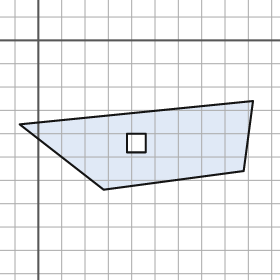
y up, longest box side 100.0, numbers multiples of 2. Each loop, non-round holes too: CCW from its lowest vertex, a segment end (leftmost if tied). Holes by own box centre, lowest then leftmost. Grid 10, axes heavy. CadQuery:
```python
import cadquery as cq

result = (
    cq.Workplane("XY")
    .moveTo(28.0, -64.0)
    .lineTo(88.0, -56.0)
    .lineTo(92.0, -26.0)
    .lineTo(-8.0, -36.0)
    .close()
    .moveTo(38.0, -48.0)
    .lineTo(46.0, -48.0)
    .lineTo(46.0, -40.0)
    .lineTo(38.0, -40.0)
    .close()
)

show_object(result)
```